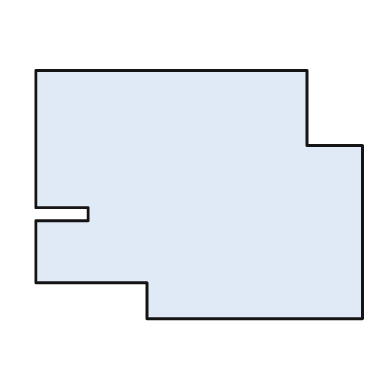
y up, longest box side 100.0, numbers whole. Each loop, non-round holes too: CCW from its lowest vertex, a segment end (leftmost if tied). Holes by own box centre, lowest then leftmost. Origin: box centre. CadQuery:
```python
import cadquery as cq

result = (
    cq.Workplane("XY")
    .moveTo(-16.0, -38.0)
    .lineTo(50.0, -38.0)
    .lineTo(50.0, 15.0)
    .lineTo(33.0, 15.0)
    .lineTo(33.0, 38.0)
    .lineTo(-50.0, 38.0)
    .lineTo(-50.0, -4.0)
    .lineTo(-34.0, -4.0)
    .lineTo(-34.0, -8.0)
    .lineTo(-50.0, -8.0)
    .lineTo(-50.0, -27.0)
    .lineTo(-16.0, -27.0)
    .close()
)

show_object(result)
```